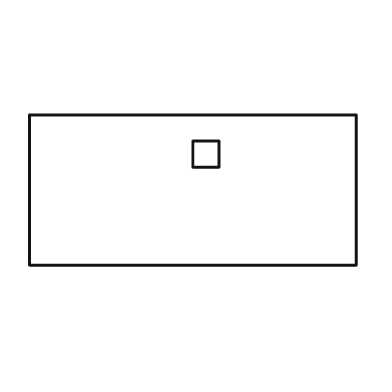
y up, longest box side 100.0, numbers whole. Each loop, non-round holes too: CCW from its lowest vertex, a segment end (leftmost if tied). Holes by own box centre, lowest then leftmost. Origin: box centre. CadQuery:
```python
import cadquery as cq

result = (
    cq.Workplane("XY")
    .moveTo(-50.0, -23.0)
    .lineTo(50.0, -23.0)
    .lineTo(50.0, 23.0)
    .lineTo(-50.0, 23.0)
    .close()
    .moveTo(0.0, 7.0)
    .lineTo(8.0, 7.0)
    .lineTo(8.0, 15.0)
    .lineTo(0.0, 15.0)
    .close()
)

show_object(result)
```